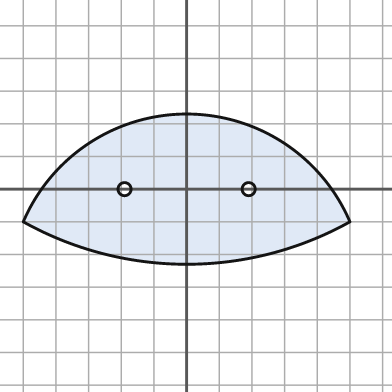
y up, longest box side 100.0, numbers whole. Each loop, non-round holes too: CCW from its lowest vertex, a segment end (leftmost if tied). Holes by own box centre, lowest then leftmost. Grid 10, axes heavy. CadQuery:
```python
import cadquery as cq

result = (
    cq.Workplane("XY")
    .moveTo(-50.0, -10.0)
    .threePointArc((0.0, -23.0), (50.0, -10.0))
    .threePointArc((0.0, 23.0), (-50.0, -10.0))
    .close()
    .moveTo(-19.0, 0.0)
    .circle(2.0)
    .moveTo(19.0, 0.0)
    .circle(2.0)
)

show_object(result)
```